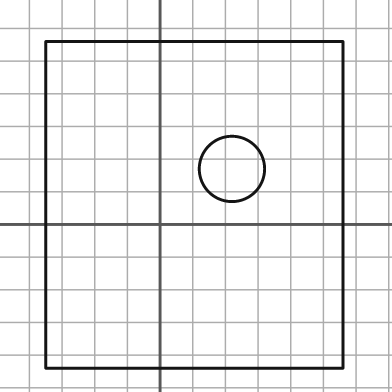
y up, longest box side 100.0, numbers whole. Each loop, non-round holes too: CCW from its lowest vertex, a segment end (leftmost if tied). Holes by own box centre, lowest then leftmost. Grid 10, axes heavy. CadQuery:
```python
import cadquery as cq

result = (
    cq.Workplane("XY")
    .moveTo(-35.0, -44.0)
    .lineTo(56.0, -44.0)
    .lineTo(56.0, 56.0)
    .lineTo(-35.0, 56.0)
    .close()
    .moveTo(22.0, 17.0)
    .circle(10.0)
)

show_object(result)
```